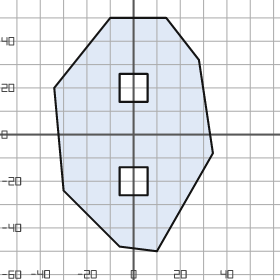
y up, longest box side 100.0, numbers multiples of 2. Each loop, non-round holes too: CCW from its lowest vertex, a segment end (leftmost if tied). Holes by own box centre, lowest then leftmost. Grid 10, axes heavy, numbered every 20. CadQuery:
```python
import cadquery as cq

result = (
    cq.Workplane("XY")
    .moveTo(10.0, -50.0)
    .lineTo(34.0, -8.0)
    .lineTo(28.0, 32.0)
    .lineTo(14.0, 50.0)
    .lineTo(-10.0, 50.0)
    .lineTo(-34.0, 20.0)
    .lineTo(-30.0, -24.0)
    .lineTo(-6.0, -48.0)
    .close()
    .moveTo(-6.0, -26.0)
    .lineTo(6.0, -26.0)
    .lineTo(6.0, -14.0)
    .lineTo(-6.0, -14.0)
    .close()
    .moveTo(-6.0, 14.0)
    .lineTo(6.0, 14.0)
    .lineTo(6.0, 26.0)
    .lineTo(-6.0, 26.0)
    .close()
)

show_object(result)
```